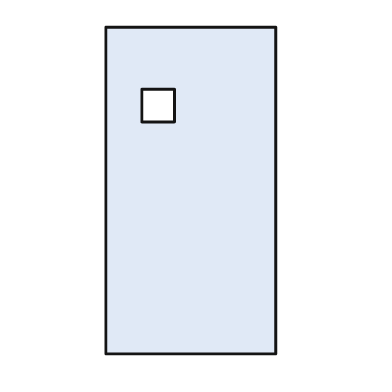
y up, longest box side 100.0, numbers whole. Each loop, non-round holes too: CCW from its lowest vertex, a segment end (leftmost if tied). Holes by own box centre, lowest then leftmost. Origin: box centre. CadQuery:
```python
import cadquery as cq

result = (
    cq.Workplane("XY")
    .moveTo(-26.0, -50.0)
    .lineTo(26.0, -50.0)
    .lineTo(26.0, 50.0)
    .lineTo(-26.0, 50.0)
    .close()
    .moveTo(-15.0, 21.0)
    .lineTo(-5.0, 21.0)
    .lineTo(-5.0, 31.0)
    .lineTo(-15.0, 31.0)
    .close()
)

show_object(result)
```